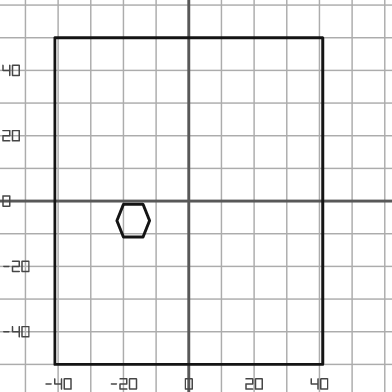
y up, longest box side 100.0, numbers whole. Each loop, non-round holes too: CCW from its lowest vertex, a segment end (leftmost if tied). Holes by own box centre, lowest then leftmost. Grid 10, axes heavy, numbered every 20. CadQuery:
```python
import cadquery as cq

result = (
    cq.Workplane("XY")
    .moveTo(-41.0, -50.0)
    .lineTo(41.0, -50.0)
    .lineTo(41.0, 50.0)
    .lineTo(-41.0, 50.0)
    .close()
    .moveTo(-20.0, -11.0)
    .lineTo(-14.0, -11.0)
    .lineTo(-12.0, -6.0)
    .lineTo(-14.0, -1.0)
    .lineTo(-20.0, -1.0)
    .lineTo(-22.0, -6.0)
    .close()
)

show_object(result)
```